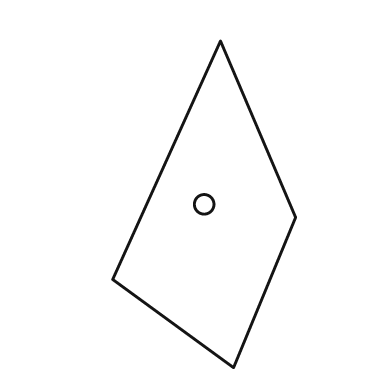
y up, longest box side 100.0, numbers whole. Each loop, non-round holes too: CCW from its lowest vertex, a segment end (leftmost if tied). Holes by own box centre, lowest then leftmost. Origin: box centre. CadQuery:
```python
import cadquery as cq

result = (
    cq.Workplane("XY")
    .moveTo(9.0, -50.0)
    .lineTo(28.0, -4.0)
    .lineTo(5.0, 50.0)
    .lineTo(-28.0, -23.0)
    .close()
    .moveTo(0.0, 0.0)
    .circle(3.0)
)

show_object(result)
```